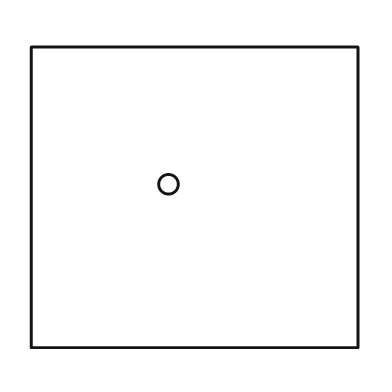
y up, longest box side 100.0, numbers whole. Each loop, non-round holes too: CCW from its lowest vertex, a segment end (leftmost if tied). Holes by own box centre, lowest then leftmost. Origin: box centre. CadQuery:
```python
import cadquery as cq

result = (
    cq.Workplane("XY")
    .moveTo(-50.0, -46.0)
    .lineTo(50.0, -46.0)
    .lineTo(50.0, 46.0)
    .lineTo(-50.0, 46.0)
    .close()
    .moveTo(-8.0, 4.0)
    .circle(3.0)
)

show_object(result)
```